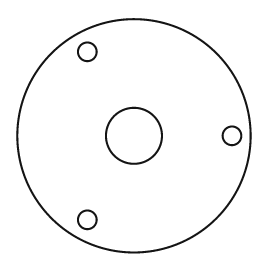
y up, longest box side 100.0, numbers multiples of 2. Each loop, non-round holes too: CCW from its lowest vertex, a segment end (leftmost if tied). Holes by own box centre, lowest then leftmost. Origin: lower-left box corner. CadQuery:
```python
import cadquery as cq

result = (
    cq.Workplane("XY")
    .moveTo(50.0, 50.0)
    .circle(50.0)
    .moveTo(30.0, 14.0)
    .circle(4.0)
    .moveTo(50.0, 50.0)
    .circle(12.0)
    .moveTo(92.0, 50.0)
    .circle(4.0)
    .moveTo(30.0, 86.0)
    .circle(4.0)
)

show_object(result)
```